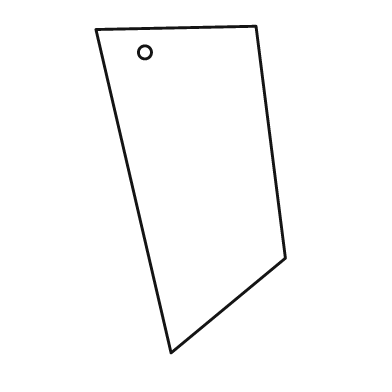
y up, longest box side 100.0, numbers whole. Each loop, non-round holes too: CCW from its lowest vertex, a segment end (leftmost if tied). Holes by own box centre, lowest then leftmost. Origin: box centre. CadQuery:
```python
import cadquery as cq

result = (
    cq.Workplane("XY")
    .moveTo(-6.0, -50.0)
    .lineTo(29.0, -21.0)
    .lineTo(20.0, 50.0)
    .lineTo(-29.0, 49.0)
    .close()
    .moveTo(-14.0, 42.0)
    .circle(2.0)
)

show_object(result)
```